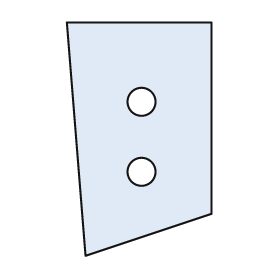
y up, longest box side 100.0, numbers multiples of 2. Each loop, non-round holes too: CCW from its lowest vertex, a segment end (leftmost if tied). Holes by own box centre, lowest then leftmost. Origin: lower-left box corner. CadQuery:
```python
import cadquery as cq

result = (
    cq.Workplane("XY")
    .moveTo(8.0, 0.0)
    .lineTo(62.0, 18.0)
    .lineTo(62.0, 100.0)
    .lineTo(0.0, 100.0)
    .close()
    .moveTo(32.0, 36.0)
    .circle(6.0)
    .moveTo(32.0, 66.0)
    .circle(6.0)
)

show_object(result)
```